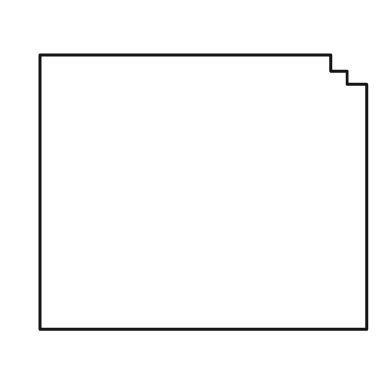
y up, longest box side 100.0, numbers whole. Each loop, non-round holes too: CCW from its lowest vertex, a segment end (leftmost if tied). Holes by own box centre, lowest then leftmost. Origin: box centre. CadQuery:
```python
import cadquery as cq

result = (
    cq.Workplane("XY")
    .moveTo(-50.0, -42.0)
    .lineTo(50.0, -42.0)
    .lineTo(50.0, 33.0)
    .lineTo(44.0, 33.0)
    .lineTo(44.0, 37.0)
    .lineTo(39.0, 37.0)
    .lineTo(39.0, 42.0)
    .lineTo(-50.0, 42.0)
    .close()
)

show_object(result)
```